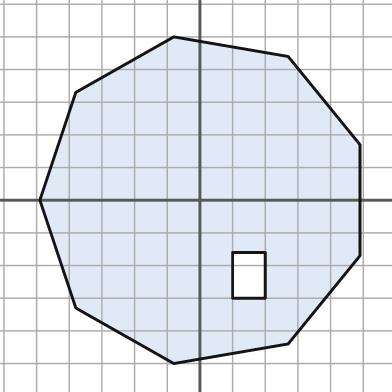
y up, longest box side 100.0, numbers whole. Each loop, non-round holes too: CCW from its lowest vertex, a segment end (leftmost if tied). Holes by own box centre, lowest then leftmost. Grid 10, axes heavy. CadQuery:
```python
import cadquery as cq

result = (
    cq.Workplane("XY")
    .moveTo(-8.0, -50.0)
    .lineTo(27.0, -44.0)
    .lineTo(49.0, -17.0)
    .lineTo(49.0, 17.0)
    .lineTo(27.0, 44.0)
    .lineTo(-8.0, 50.0)
    .lineTo(-38.0, 33.0)
    .lineTo(-49.0, 0.0)
    .lineTo(-38.0, -33.0)
    .close()
    .moveTo(10.0, -30.0)
    .lineTo(20.0, -30.0)
    .lineTo(20.0, -16.0)
    .lineTo(10.0, -16.0)
    .close()
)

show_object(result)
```